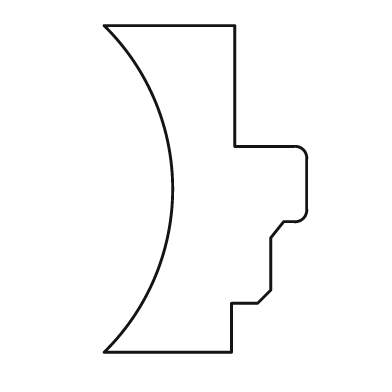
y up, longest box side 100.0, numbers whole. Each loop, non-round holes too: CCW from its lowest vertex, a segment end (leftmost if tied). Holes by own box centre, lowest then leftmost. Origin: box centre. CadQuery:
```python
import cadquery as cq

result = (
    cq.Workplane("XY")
    .moveTo(-31.0, -50.0)
    .lineTo(8.0, -50.0)
    .lineTo(8.0, -35.0)
    .lineTo(16.0, -35.0)
    .lineTo(20.0, -31.0)
    .lineTo(20.0, -15.0)
    .lineTo(24.0, -10.0)
    .lineTo(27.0, -10.0)
    .threePointArc((30.0, -9.0), (31.0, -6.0))
    .lineTo(31.0, 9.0)
    .threePointArc((30.0, 12.0), (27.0, 13.0))
    .lineTo(9.0, 13.0)
    .lineTo(9.0, 50.0)
    .lineTo(-31.0, 50.0)
    .threePointArc((-10.0, 0.0), (-31.0, -50.0))
    .close()
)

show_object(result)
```